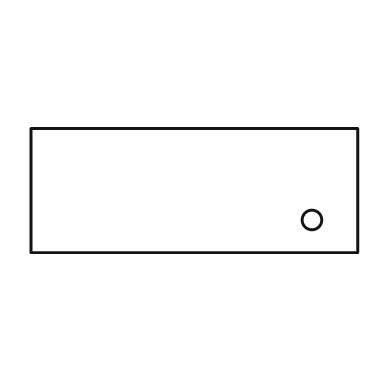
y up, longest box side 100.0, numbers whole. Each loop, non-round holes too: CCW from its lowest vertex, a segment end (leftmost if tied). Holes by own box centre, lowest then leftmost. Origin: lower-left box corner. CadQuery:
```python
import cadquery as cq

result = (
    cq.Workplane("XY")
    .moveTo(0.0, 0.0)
    .lineTo(100.0, 0.0)
    .lineTo(100.0, 38.0)
    .lineTo(0.0, 38.0)
    .close()
    .moveTo(86.0, 10.0)
    .circle(3.0)
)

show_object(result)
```